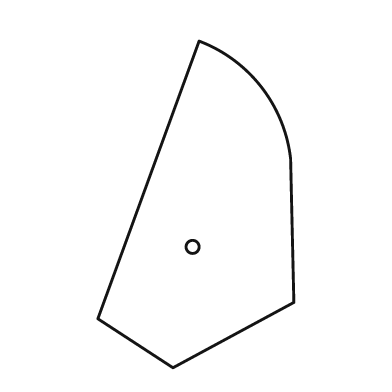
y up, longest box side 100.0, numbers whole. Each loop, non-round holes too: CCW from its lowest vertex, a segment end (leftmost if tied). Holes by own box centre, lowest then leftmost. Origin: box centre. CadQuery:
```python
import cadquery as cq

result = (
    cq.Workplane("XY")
    .moveTo(-7.0, -50.0)
    .lineTo(30.0, -30.0)
    .lineTo(29.0, 14.0)
    .threePointArc((20.0, 36.0), (1.0, 50.0))
    .lineTo(-30.0, -35.0)
    .close()
    .moveTo(-1.0, -13.0)
    .circle(2.0)
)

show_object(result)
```